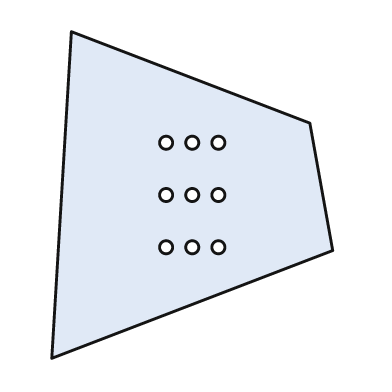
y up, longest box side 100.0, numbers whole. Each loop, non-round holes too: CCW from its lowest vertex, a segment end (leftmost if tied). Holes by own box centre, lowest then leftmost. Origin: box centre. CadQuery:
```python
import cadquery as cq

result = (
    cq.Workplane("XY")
    .moveTo(-43.0, -50.0)
    .lineTo(43.0, -17.0)
    .lineTo(36.0, 22.0)
    .lineTo(-37.0, 50.0)
    .close()
    .moveTo(-8.0, -16.0)
    .circle(2.0)
    .moveTo(0.0, -16.0)
    .circle(2.0)
    .moveTo(8.0, -16.0)
    .circle(2.0)
    .moveTo(-8.0, 0.0)
    .circle(2.0)
    .moveTo(0.0, 0.0)
    .circle(2.0)
    .moveTo(8.0, 0.0)
    .circle(2.0)
    .moveTo(-8.0, 16.0)
    .circle(2.0)
    .moveTo(0.0, 16.0)
    .circle(2.0)
    .moveTo(8.0, 16.0)
    .circle(2.0)
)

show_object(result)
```